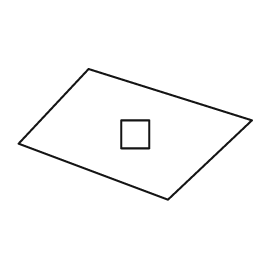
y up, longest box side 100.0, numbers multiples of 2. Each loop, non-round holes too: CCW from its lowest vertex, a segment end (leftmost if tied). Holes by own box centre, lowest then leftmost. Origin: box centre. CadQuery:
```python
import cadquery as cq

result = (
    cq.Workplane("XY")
    .moveTo(14.0, -28.0)
    .lineTo(50.0, 6.0)
    .lineTo(-20.0, 28.0)
    .lineTo(-50.0, -4.0)
    .close()
    .moveTo(-6.0, -6.0)
    .lineTo(6.0, -6.0)
    .lineTo(6.0, 6.0)
    .lineTo(-6.0, 6.0)
    .close()
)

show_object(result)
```